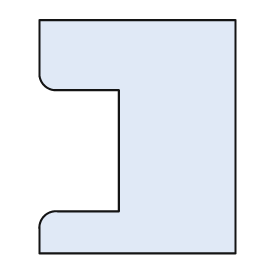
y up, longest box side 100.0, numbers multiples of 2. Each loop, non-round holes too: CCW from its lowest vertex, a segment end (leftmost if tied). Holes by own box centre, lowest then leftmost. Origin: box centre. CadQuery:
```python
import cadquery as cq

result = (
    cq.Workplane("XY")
    .moveTo(-42.0, -50.0)
    .lineTo(42.0, -50.0)
    .lineTo(42.0, 50.0)
    .lineTo(-42.0, 50.0)
    .lineTo(-42.0, 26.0)
    .threePointArc((-40.0, 22.0), (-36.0, 20.0))
    .lineTo(-8.0, 20.0)
    .lineTo(-8.0, -32.0)
    .lineTo(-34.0, -32.0)
    .threePointArc((-40.0, -34.0), (-42.0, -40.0))
    .close()
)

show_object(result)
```